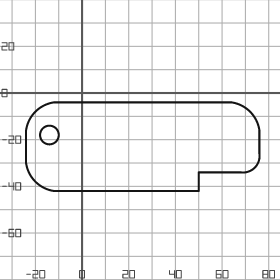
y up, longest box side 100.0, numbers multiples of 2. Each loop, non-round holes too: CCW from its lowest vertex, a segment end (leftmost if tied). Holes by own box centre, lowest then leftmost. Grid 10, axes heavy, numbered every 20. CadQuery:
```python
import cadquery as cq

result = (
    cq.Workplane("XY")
    .moveTo(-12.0, -42.0)
    .lineTo(50.0, -42.0)
    .lineTo(50.0, -34.0)
    .lineTo(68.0, -34.0)
    .threePointArc((74.0, -32.0), (76.0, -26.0))
    .lineTo(76.0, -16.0)
    .threePointArc((72.0, -8.0), (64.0, -4.0))
    .lineTo(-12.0, -4.0)
    .threePointArc((-20.0, -8.0), (-24.0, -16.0))
    .lineTo(-24.0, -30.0)
    .threePointArc((-20.0, -38.0), (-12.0, -42.0))
    .close()
    .moveTo(-14.0, -18.0)
    .circle(4.0)
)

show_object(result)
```